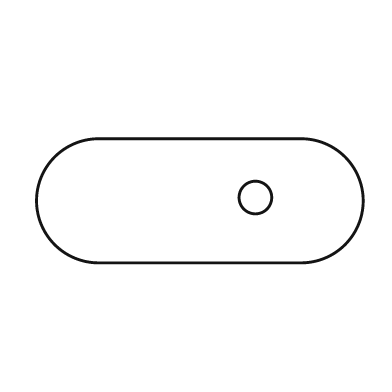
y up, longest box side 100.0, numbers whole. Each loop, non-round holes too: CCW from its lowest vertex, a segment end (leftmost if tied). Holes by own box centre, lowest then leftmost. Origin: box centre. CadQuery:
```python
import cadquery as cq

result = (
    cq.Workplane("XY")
    .moveTo(-31.0, -19.0)
    .lineTo(31.0, -19.0)
    .threePointArc((50.0, 0.0), (31.0, 19.0))
    .lineTo(-31.0, 19.0)
    .threePointArc((-50.0, 0.0), (-31.0, -19.0))
    .close()
    .moveTo(17.0, 1.0)
    .circle(5.0)
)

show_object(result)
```